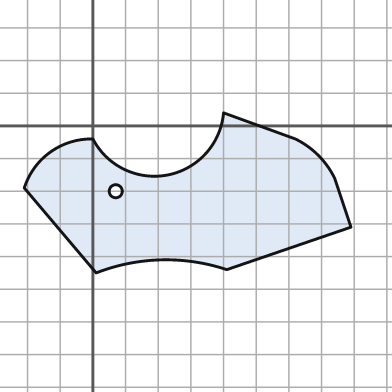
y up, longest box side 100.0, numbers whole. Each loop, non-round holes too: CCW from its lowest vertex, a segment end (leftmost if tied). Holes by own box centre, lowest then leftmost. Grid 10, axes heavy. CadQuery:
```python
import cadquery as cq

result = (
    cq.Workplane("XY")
    .moveTo(1.0, -45.0)
    .threePointArc((21.0, -41.0), (41.0, -44.0))
    .lineTo(79.0, -31.0)
    .lineTo(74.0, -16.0)
    .threePointArc((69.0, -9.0), (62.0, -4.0))
    .lineTo(40.0, 4.0)
    .threePointArc((23.0, -15.0), (0.0, -4.0))
    .threePointArc((-13.0, -8.0), (-21.0, -19.0))
    .close()
    .moveTo(7.0, -20.0)
    .circle(2.0)
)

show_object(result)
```